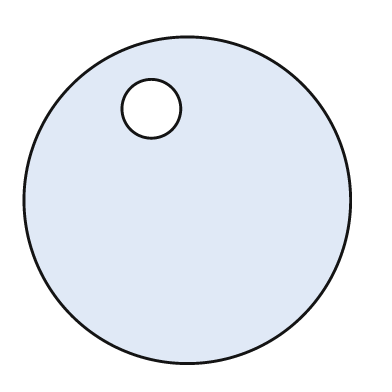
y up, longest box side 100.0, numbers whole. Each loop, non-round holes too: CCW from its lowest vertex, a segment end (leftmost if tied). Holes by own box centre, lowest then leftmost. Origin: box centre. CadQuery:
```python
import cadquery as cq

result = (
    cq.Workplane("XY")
    .moveTo(0.0, 0.0)
    .circle(50.0)
    .moveTo(-11.0, 28.0)
    .circle(9.0)
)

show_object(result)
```